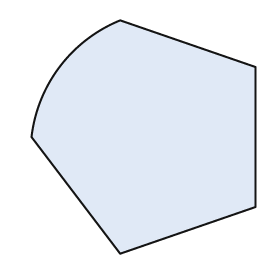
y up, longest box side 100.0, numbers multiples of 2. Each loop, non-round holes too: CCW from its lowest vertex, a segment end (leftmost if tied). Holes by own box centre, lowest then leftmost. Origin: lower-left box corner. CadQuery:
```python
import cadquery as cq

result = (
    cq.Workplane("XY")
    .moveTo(38.0, 0.0)
    .lineTo(96.0, 20.0)
    .lineTo(96.0, 80.0)
    .lineTo(38.0, 100.0)
    .threePointArc((12.0, 80.0), (0.0, 50.0))
    .close()
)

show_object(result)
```